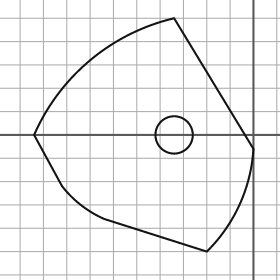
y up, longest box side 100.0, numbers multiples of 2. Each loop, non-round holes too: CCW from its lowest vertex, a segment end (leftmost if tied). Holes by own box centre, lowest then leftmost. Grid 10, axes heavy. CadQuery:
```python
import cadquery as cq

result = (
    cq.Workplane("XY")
    .moveTo(-20.0, -50.0)
    .threePointArc((-6.0, -30.0), (0.0, -6.0))
    .lineTo(-34.0, 50.0)
    .threePointArc((-70.0, 32.0), (-94.0, 0.0))
    .lineTo(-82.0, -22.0)
    .threePointArc((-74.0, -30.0), (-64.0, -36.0))
    .close()
    .moveTo(-34.0, 0.0)
    .circle(8.0)
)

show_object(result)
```